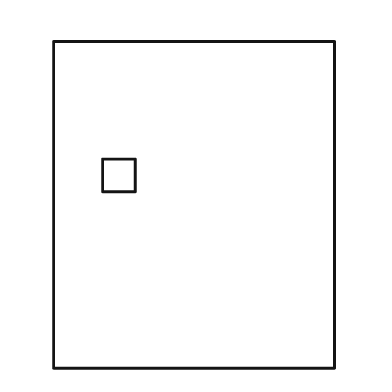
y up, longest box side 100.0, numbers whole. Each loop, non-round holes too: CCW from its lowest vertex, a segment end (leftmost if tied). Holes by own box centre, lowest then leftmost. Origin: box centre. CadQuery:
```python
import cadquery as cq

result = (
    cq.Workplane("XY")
    .moveTo(-43.0, -50.0)
    .lineTo(43.0, -50.0)
    .lineTo(43.0, 50.0)
    .lineTo(-43.0, 50.0)
    .close()
    .moveTo(-28.0, 4.0)
    .lineTo(-18.0, 4.0)
    .lineTo(-18.0, 14.0)
    .lineTo(-28.0, 14.0)
    .close()
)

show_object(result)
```